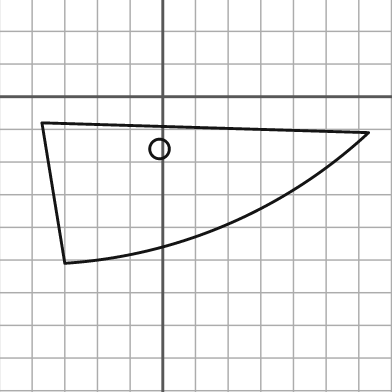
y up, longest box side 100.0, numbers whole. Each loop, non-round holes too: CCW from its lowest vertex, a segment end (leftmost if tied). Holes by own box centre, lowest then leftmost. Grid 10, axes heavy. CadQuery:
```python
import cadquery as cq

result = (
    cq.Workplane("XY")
    .moveTo(-30.0, -51.0)
    .threePointArc((20.0, -39.0), (63.0, -11.0))
    .lineTo(-37.0, -8.0)
    .close()
    .moveTo(-1.0, -16.0)
    .circle(3.0)
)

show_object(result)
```